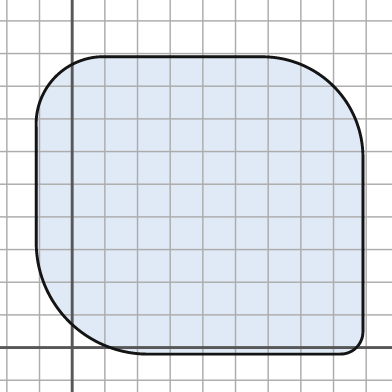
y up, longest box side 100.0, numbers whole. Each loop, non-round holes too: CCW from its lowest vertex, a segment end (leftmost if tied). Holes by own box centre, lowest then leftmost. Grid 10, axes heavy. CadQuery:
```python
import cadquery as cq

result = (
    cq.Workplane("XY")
    .moveTo(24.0, -2.0)
    .lineTo(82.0, -2.0)
    .threePointArc((87.0, 0.0), (89.0, 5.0))
    .lineTo(89.0, 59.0)
    .threePointArc((80.0, 80.0), (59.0, 89.0))
    .lineTo(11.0, 89.0)
    .threePointArc((-5.0, 83.0), (-11.0, 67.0))
    .lineTo(-11.0, 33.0)
    .threePointArc((-1.0, 8.0), (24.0, -2.0))
    .close()
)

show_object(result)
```